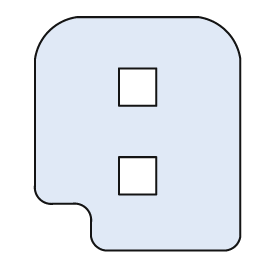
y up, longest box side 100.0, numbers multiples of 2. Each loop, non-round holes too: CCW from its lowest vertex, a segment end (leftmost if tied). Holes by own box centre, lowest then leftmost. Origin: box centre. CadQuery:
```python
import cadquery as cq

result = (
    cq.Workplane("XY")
    .moveTo(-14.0, -50.0)
    .lineTo(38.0, -50.0)
    .threePointArc((42.0, -48.0), (44.0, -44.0))
    .lineTo(44.0, 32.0)
    .threePointArc((38.0, 44.0), (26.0, 50.0))
    .lineTo(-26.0, 50.0)
    .threePointArc((-38.0, 44.0), (-44.0, 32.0))
    .lineTo(-44.0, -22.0)
    .threePointArc((-42.0, -28.0), (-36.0, -30.0))
    .lineTo(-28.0, -30.0)
    .threePointArc((-22.0, -32.0), (-20.0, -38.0))
    .lineTo(-20.0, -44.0)
    .threePointArc((-18.0, -48.0), (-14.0, -50.0))
    .close()
    .moveTo(-8.0, -26.0)
    .lineTo(8.0, -26.0)
    .lineTo(8.0, -10.0)
    .lineTo(-8.0, -10.0)
    .close()
    .moveTo(-8.0, 12.0)
    .lineTo(8.0, 12.0)
    .lineTo(8.0, 28.0)
    .lineTo(-8.0, 28.0)
    .close()
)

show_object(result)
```